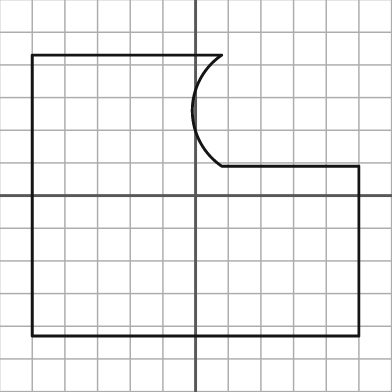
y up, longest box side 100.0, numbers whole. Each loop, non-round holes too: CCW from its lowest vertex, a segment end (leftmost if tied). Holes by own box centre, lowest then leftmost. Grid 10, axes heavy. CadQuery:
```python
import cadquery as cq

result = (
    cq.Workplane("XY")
    .moveTo(-50.0, -43.0)
    .lineTo(50.0, -43.0)
    .lineTo(50.0, 9.0)
    .lineTo(8.0, 9.0)
    .threePointArc((-1.0, 26.0), (8.0, 43.0))
    .lineTo(-50.0, 43.0)
    .close()
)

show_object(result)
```